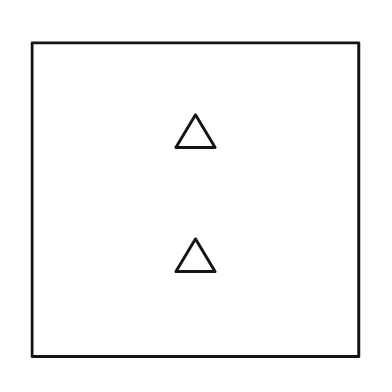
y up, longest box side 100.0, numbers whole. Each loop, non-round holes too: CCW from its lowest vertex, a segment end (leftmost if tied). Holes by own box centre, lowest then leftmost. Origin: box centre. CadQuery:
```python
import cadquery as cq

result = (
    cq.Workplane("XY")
    .moveTo(-50.0, -48.0)
    .lineTo(50.0, -48.0)
    .lineTo(50.0, 48.0)
    .lineTo(-50.0, 48.0)
    .close()
    .moveTo(-6.0, -22.0)
    .lineTo(6.0, -22.0)
    .lineTo(0.0, -12.0)
    .close()
    .moveTo(-6.0, 16.0)
    .lineTo(6.0, 16.0)
    .lineTo(0.0, 26.0)
    .close()
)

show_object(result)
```